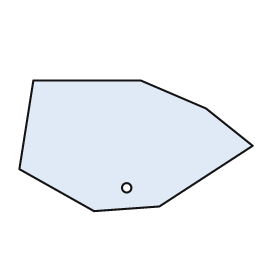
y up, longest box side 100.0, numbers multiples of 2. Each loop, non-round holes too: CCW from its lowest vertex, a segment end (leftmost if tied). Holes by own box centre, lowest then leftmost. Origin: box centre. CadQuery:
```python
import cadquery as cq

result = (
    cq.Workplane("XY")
    .moveTo(-18.0, -28.0)
    .lineTo(10.0, -26.0)
    .lineTo(50.0, 0.0)
    .lineTo(30.0, 16.0)
    .lineTo(2.0, 28.0)
    .lineTo(-44.0, 28.0)
    .lineTo(-50.0, -10.0)
    .close()
    .moveTo(-4.0, -18.0)
    .circle(2.0)
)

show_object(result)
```